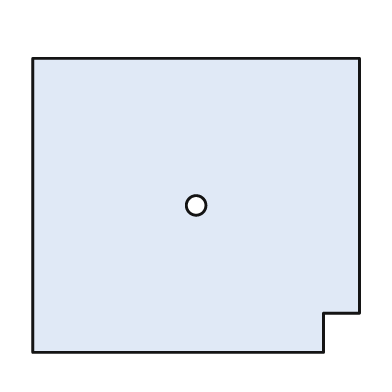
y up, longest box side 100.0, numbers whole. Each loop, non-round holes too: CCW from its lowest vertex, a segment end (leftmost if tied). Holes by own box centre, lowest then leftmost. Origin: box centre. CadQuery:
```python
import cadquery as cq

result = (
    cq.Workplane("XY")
    .moveTo(-50.0, -45.0)
    .lineTo(39.0, -45.0)
    .lineTo(39.0, -33.0)
    .lineTo(50.0, -33.0)
    .lineTo(50.0, 45.0)
    .lineTo(-50.0, 45.0)
    .close()
    .moveTo(0.0, 0.0)
    .circle(3.0)
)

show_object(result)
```